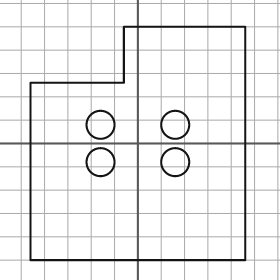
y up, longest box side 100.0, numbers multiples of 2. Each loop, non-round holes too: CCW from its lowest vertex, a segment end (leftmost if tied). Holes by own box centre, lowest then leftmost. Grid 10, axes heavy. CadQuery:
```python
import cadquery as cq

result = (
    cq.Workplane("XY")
    .moveTo(-46.0, -50.0)
    .lineTo(46.0, -50.0)
    .lineTo(46.0, 50.0)
    .lineTo(-6.0, 50.0)
    .lineTo(-6.0, 26.0)
    .lineTo(-46.0, 26.0)
    .close()
    .moveTo(-16.0, -8.0)
    .circle(6.0)
    .moveTo(16.0, -8.0)
    .circle(6.0)
    .moveTo(-16.0, 8.0)
    .circle(6.0)
    .moveTo(16.0, 8.0)
    .circle(6.0)
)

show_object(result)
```